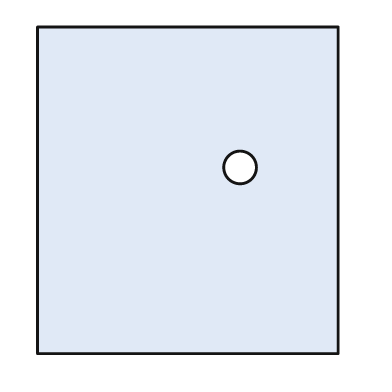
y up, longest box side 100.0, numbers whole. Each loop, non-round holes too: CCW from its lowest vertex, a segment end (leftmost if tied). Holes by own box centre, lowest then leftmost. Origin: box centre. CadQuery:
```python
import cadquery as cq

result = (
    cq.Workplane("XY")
    .moveTo(-46.0, -50.0)
    .lineTo(46.0, -50.0)
    .lineTo(46.0, 50.0)
    .lineTo(-46.0, 50.0)
    .close()
    .moveTo(16.0, 7.0)
    .circle(5.0)
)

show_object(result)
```